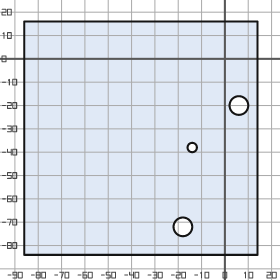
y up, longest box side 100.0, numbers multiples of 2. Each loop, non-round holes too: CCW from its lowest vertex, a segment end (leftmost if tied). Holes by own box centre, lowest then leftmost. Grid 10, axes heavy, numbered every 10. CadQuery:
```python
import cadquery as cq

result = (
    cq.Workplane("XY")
    .moveTo(-86.0, -84.0)
    .lineTo(14.0, -84.0)
    .lineTo(14.0, 16.0)
    .lineTo(-86.0, 16.0)
    .close()
    .moveTo(-18.0, -72.0)
    .circle(4.0)
    .moveTo(-14.0, -38.0)
    .circle(2.0)
    .moveTo(6.0, -20.0)
    .circle(4.0)
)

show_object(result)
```